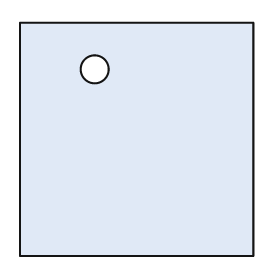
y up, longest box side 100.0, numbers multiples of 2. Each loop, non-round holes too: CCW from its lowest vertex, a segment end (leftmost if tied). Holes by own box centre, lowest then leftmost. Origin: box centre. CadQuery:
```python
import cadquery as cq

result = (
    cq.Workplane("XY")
    .moveTo(-50.0, -50.0)
    .lineTo(50.0, -50.0)
    .lineTo(50.0, 50.0)
    .lineTo(-50.0, 50.0)
    .close()
    .moveTo(-18.0, 30.0)
    .circle(6.0)
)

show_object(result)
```